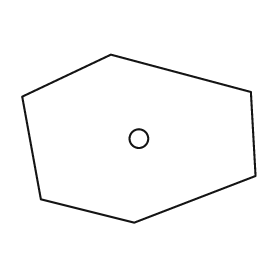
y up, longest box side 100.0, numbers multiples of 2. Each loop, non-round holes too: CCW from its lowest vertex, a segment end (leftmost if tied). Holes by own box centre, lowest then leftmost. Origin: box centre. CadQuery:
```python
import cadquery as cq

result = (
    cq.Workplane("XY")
    .moveTo(-2.0, -36.0)
    .lineTo(50.0, -16.0)
    .lineTo(48.0, 20.0)
    .lineTo(-12.0, 36.0)
    .lineTo(-50.0, 18.0)
    .lineTo(-42.0, -26.0)
    .close()
    .moveTo(0.0, 0.0)
    .circle(4.0)
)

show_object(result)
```